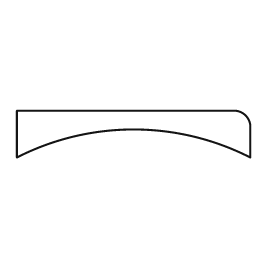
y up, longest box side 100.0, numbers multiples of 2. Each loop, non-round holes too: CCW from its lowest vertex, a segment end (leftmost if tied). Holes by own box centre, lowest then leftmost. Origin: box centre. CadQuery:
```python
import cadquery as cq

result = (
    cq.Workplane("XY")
    .moveTo(-50.0, -10.0)
    .threePointArc((0.0, 2.0), (50.0, -10.0))
    .lineTo(50.0, 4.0)
    .threePointArc((48.0, 8.0), (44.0, 10.0))
    .lineTo(-50.0, 10.0)
    .close()
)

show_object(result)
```